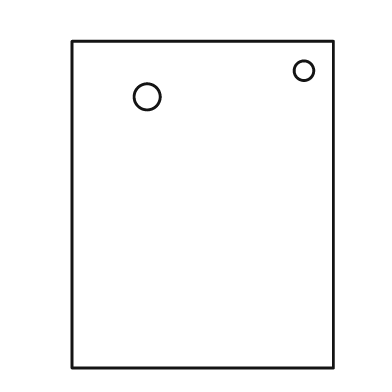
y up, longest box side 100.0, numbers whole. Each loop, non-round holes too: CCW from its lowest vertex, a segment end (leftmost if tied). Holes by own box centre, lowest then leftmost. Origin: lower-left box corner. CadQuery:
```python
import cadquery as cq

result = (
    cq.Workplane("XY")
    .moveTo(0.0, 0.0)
    .lineTo(80.0, 0.0)
    .lineTo(80.0, 100.0)
    .lineTo(0.0, 100.0)
    .close()
    .moveTo(23.0, 83.0)
    .circle(4.0)
    .moveTo(71.0, 91.0)
    .circle(3.0)
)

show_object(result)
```